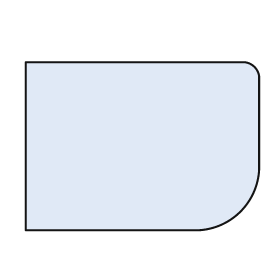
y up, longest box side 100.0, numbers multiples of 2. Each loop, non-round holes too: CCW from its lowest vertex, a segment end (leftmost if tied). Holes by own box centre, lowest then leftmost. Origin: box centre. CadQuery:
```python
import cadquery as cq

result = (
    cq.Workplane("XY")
    .moveTo(-50.0, -36.0)
    .lineTo(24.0, -36.0)
    .threePointArc((42.0, -28.0), (50.0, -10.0))
    .lineTo(50.0, 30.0)
    .threePointArc((48.0, 34.0), (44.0, 36.0))
    .lineTo(-50.0, 36.0)
    .close()
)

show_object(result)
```